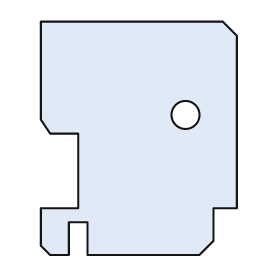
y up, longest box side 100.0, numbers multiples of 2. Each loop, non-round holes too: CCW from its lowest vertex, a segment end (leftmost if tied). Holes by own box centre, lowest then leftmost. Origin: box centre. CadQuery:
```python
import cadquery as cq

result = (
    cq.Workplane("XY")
    .moveTo(-38.0, -50.0)
    .lineTo(-30.0, -50.0)
    .lineTo(-30.0, -36.0)
    .lineTo(-22.0, -36.0)
    .lineTo(-22.0, -50.0)
    .lineTo(26.0, -50.0)
    .lineTo(32.0, -44.0)
    .lineTo(32.0, -30.0)
    .lineTo(42.0, -30.0)
    .lineTo(42.0, 44.0)
    .lineTo(36.0, 50.0)
    .lineTo(-42.0, 50.0)
    .lineTo(-42.0, 8.0)
    .lineTo(-38.0, 2.0)
    .lineTo(-26.0, 2.0)
    .lineTo(-26.0, -30.0)
    .lineTo(-42.0, -30.0)
    .lineTo(-42.0, -46.0)
    .close()
    .moveTo(20.0, 10.0)
    .circle(6.0)
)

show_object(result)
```